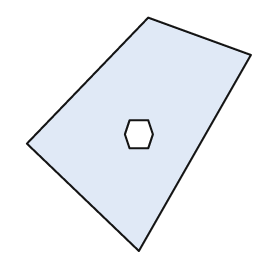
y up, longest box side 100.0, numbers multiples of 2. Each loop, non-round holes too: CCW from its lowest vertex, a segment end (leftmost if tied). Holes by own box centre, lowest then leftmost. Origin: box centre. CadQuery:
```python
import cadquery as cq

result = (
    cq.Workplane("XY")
    .moveTo(0.0, -50.0)
    .lineTo(48.0, 34.0)
    .lineTo(4.0, 50.0)
    .lineTo(-48.0, -4.0)
    .close()
    .moveTo(-4.0, -6.0)
    .lineTo(4.0, -6.0)
    .lineTo(6.0, 0.0)
    .lineTo(4.0, 6.0)
    .lineTo(-4.0, 6.0)
    .lineTo(-6.0, 0.0)
    .close()
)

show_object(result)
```